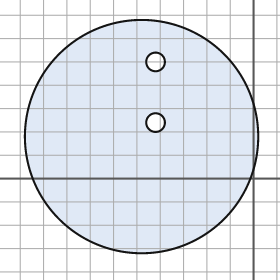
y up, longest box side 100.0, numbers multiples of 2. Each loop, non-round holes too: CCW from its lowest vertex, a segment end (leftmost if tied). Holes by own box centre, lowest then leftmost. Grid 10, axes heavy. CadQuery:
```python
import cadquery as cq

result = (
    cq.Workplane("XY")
    .moveTo(-48.0, 18.0)
    .circle(50.0)
    .moveTo(-42.0, 24.0)
    .circle(4.0)
    .moveTo(-42.0, 50.0)
    .circle(4.0)
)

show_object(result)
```